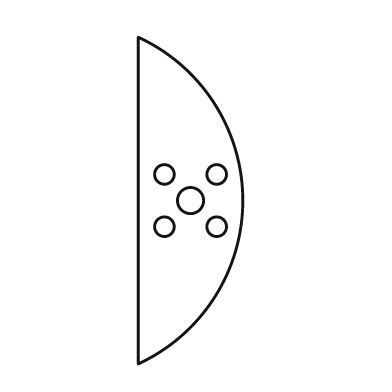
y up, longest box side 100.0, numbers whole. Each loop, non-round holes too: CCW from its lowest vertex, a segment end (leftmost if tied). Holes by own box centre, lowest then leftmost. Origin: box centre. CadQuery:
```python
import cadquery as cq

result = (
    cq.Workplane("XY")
    .moveTo(-16.0, -50.0)
    .threePointArc((16.0, 0.0), (-16.0, 50.0))
    .close()
    .moveTo(-8.0, -8.0)
    .circle(3.0)
    .moveTo(8.0, -8.0)
    .circle(3.0)
    .moveTo(0.0, 0.0)
    .circle(4.0)
    .moveTo(-8.0, 8.0)
    .circle(3.0)
    .moveTo(8.0, 8.0)
    .circle(3.0)
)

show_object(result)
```